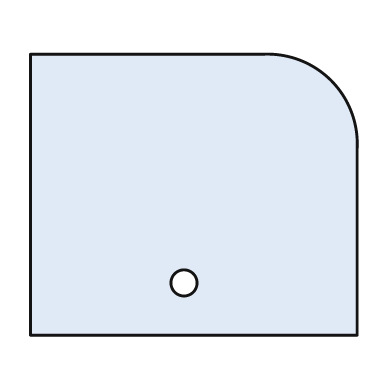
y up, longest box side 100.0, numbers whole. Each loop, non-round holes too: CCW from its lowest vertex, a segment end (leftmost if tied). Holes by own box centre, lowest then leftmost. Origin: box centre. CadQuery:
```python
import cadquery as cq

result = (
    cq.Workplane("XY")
    .moveTo(-50.0, -43.0)
    .lineTo(50.0, -43.0)
    .lineTo(50.0, 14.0)
    .threePointArc((42.0, 35.0), (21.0, 43.0))
    .lineTo(-50.0, 43.0)
    .close()
    .moveTo(-3.0, -27.0)
    .circle(4.0)
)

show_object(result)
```